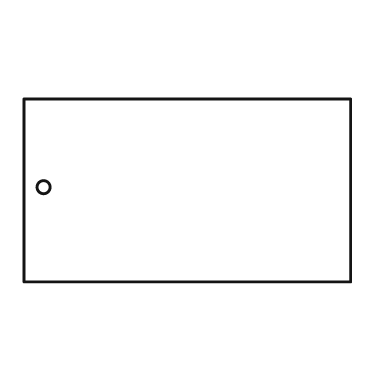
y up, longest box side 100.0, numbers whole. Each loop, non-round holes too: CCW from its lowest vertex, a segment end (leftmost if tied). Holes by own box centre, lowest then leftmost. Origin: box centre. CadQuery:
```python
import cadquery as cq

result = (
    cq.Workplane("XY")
    .moveTo(-50.0, -28.0)
    .lineTo(50.0, -28.0)
    .lineTo(50.0, 28.0)
    .lineTo(-50.0, 28.0)
    .close()
    .moveTo(-44.0, 1.0)
    .circle(2.0)
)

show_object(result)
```